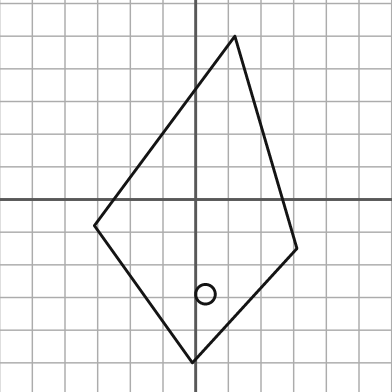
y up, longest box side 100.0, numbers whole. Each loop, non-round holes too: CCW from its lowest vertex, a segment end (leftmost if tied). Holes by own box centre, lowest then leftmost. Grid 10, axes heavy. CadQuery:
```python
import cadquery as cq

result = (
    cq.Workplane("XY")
    .moveTo(-1.0, -50.0)
    .lineTo(31.0, -15.0)
    .lineTo(12.0, 50.0)
    .lineTo(-31.0, -8.0)
    .close()
    .moveTo(3.0, -29.0)
    .circle(3.0)
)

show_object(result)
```